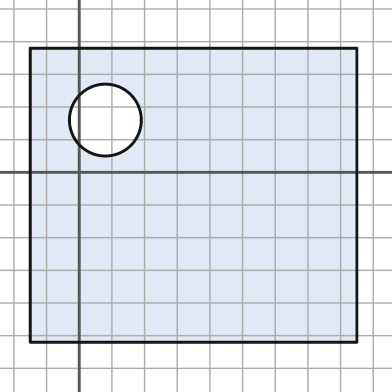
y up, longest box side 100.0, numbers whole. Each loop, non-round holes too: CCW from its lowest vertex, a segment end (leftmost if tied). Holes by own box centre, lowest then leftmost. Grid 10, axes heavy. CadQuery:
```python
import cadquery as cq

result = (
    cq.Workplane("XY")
    .moveTo(-15.0, -52.0)
    .lineTo(85.0, -52.0)
    .lineTo(85.0, 38.0)
    .lineTo(-15.0, 38.0)
    .close()
    .moveTo(8.0, 16.0)
    .circle(11.0)
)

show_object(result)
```